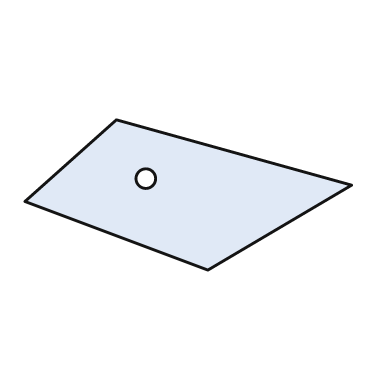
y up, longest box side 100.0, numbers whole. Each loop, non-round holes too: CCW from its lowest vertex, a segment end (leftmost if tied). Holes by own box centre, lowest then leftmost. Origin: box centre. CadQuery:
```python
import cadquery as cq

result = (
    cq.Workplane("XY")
    .moveTo(6.0, -23.0)
    .lineTo(50.0, 3.0)
    .lineTo(-22.0, 23.0)
    .lineTo(-50.0, -2.0)
    .close()
    .moveTo(-13.0, 5.0)
    .circle(3.0)
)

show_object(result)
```